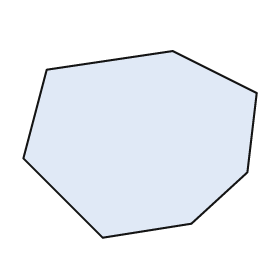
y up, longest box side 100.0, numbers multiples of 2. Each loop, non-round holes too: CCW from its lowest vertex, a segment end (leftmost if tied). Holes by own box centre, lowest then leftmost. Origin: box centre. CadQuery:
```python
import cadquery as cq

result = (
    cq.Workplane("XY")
    .moveTo(-16.0, -40.0)
    .lineTo(22.0, -34.0)
    .lineTo(46.0, -12.0)
    .lineTo(50.0, 22.0)
    .lineTo(14.0, 40.0)
    .lineTo(-40.0, 32.0)
    .lineTo(-50.0, -6.0)
    .close()
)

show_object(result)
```